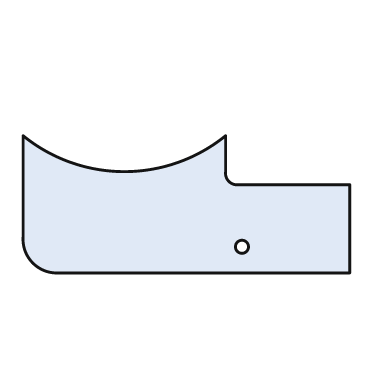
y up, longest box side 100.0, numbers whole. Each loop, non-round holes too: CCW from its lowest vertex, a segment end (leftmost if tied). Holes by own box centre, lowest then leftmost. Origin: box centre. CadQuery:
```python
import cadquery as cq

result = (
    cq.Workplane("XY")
    .moveTo(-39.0, -21.0)
    .lineTo(50.0, -21.0)
    .lineTo(50.0, 6.0)
    .lineTo(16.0, 6.0)
    .threePointArc((13.0, 7.0), (12.0, 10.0))
    .lineTo(12.0, 21.0)
    .threePointArc((-19.0, 10.0), (-50.0, 21.0))
    .lineTo(-50.0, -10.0)
    .threePointArc((-47.0, -18.0), (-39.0, -21.0))
    .close()
    .moveTo(17.0, -13.0)
    .circle(2.0)
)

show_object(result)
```